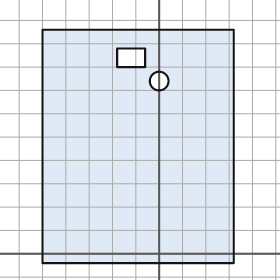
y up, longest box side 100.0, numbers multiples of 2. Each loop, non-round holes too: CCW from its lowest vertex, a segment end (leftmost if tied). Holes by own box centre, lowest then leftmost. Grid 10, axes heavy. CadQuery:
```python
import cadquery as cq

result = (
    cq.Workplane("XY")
    .moveTo(-50.0, -4.0)
    .lineTo(32.0, -4.0)
    .lineTo(32.0, 96.0)
    .lineTo(-50.0, 96.0)
    .close()
    .moveTo(0.0, 74.0)
    .circle(4.0)
    .moveTo(-18.0, 80.0)
    .lineTo(-6.0, 80.0)
    .lineTo(-6.0, 88.0)
    .lineTo(-18.0, 88.0)
    .close()
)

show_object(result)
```